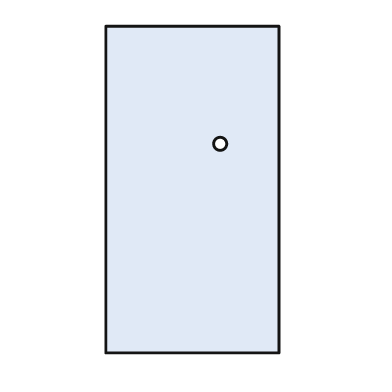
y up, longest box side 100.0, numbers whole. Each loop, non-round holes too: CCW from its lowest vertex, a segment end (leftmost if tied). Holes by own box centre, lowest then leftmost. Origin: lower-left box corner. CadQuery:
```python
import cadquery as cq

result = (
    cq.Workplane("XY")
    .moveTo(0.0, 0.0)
    .lineTo(53.0, 0.0)
    .lineTo(53.0, 100.0)
    .lineTo(0.0, 100.0)
    .close()
    .moveTo(35.0, 64.0)
    .circle(2.0)
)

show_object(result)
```